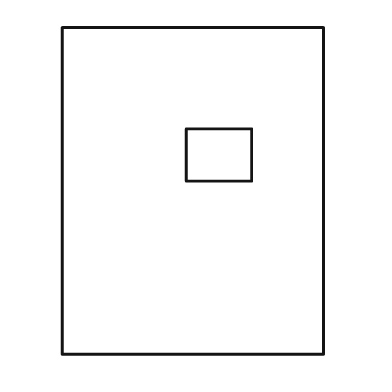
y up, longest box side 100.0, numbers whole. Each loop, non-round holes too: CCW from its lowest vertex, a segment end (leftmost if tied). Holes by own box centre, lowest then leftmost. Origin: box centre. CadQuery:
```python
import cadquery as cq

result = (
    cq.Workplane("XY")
    .moveTo(-40.0, -50.0)
    .lineTo(40.0, -50.0)
    .lineTo(40.0, 50.0)
    .lineTo(-40.0, 50.0)
    .close()
    .moveTo(-2.0, 3.0)
    .lineTo(18.0, 3.0)
    .lineTo(18.0, 19.0)
    .lineTo(-2.0, 19.0)
    .close()
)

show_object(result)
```